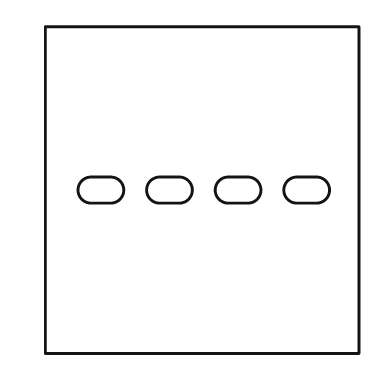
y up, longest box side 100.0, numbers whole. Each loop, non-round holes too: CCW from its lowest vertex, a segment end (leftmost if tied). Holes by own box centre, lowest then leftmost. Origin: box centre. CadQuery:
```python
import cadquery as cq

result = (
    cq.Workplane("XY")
    .moveTo(-48.0, -50.0)
    .lineTo(48.0, -50.0)
    .lineTo(48.0, 50.0)
    .lineTo(-48.0, 50.0)
    .close()
    .moveTo(-34.0, -4.0)
    .lineTo(-28.0, -4.0)
    .threePointArc((-24.0, 0.0), (-28.0, 4.0))
    .lineTo(-34.0, 4.0)
    .threePointArc((-38.0, 0.0), (-34.0, -4.0))
    .close()
    .moveTo(-13.0, -4.0)
    .lineTo(-7.0, -4.0)
    .threePointArc((-3.0, 0.0), (-7.0, 4.0))
    .lineTo(-13.0, 4.0)
    .threePointArc((-17.0, 0.0), (-13.0, -4.0))
    .close()
    .moveTo(8.0, -4.0)
    .lineTo(14.0, -4.0)
    .threePointArc((18.0, 0.0), (14.0, 4.0))
    .lineTo(8.0, 4.0)
    .threePointArc((4.0, 0.0), (8.0, -4.0))
    .close()
    .moveTo(29.0, -4.0)
    .lineTo(35.0, -4.0)
    .threePointArc((39.0, 0.0), (35.0, 4.0))
    .lineTo(29.0, 4.0)
    .threePointArc((25.0, 0.0), (29.0, -4.0))
    .close()
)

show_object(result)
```